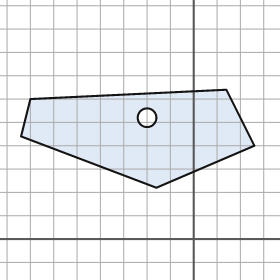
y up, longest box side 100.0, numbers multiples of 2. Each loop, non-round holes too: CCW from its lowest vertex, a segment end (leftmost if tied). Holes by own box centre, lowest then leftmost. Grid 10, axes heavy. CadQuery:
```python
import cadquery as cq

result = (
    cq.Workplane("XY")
    .moveTo(-16.0, 22.0)
    .lineTo(26.0, 40.0)
    .lineTo(14.0, 64.0)
    .lineTo(-70.0, 60.0)
    .lineTo(-74.0, 44.0)
    .close()
    .moveTo(-20.0, 52.0)
    .circle(4.0)
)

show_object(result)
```